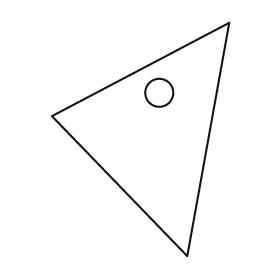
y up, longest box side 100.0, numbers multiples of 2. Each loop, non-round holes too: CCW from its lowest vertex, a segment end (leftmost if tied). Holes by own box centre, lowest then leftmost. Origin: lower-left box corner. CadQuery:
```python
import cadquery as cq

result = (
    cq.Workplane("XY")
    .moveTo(58.0, 0.0)
    .lineTo(76.0, 100.0)
    .lineTo(0.0, 60.0)
    .close()
    .moveTo(46.0, 70.0)
    .circle(6.0)
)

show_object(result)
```